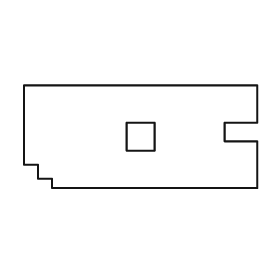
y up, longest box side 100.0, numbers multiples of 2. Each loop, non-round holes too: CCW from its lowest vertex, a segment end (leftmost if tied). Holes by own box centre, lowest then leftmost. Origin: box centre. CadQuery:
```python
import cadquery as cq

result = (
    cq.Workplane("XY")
    .moveTo(-38.0, -22.0)
    .lineTo(50.0, -22.0)
    .lineTo(50.0, -2.0)
    .lineTo(36.0, -2.0)
    .lineTo(36.0, 6.0)
    .lineTo(50.0, 6.0)
    .lineTo(50.0, 22.0)
    .lineTo(-50.0, 22.0)
    .lineTo(-50.0, -12.0)
    .lineTo(-44.0, -12.0)
    .lineTo(-44.0, -18.0)
    .lineTo(-38.0, -18.0)
    .close()
    .moveTo(-6.0, -6.0)
    .lineTo(6.0, -6.0)
    .lineTo(6.0, 6.0)
    .lineTo(-6.0, 6.0)
    .close()
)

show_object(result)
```